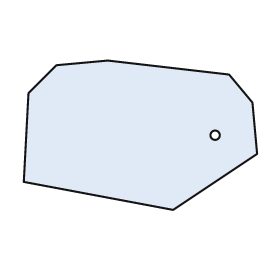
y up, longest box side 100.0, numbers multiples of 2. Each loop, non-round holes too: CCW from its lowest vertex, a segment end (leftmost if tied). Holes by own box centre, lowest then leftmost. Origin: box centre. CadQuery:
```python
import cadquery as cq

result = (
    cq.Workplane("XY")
    .moveTo(14.0, -32.0)
    .lineTo(50.0, -8.0)
    .lineTo(48.0, 14.0)
    .lineTo(38.0, 26.0)
    .lineTo(-14.0, 32.0)
    .lineTo(-36.0, 30.0)
    .lineTo(-48.0, 18.0)
    .lineTo(-50.0, -20.0)
    .close()
    .moveTo(32.0, 0.0)
    .circle(2.0)
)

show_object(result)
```